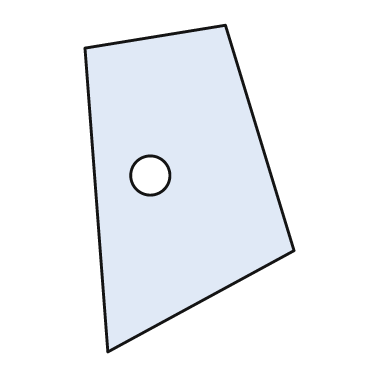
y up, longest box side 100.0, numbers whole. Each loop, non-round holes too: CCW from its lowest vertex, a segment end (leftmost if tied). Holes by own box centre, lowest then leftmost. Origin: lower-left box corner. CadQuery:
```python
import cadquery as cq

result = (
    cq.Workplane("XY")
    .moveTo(7.0, 0.0)
    .lineTo(64.0, 31.0)
    .lineTo(43.0, 100.0)
    .lineTo(0.0, 93.0)
    .close()
    .moveTo(20.0, 54.0)
    .circle(6.0)
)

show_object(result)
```